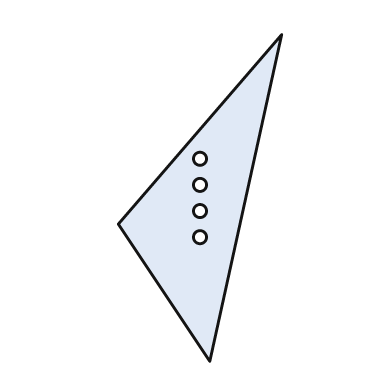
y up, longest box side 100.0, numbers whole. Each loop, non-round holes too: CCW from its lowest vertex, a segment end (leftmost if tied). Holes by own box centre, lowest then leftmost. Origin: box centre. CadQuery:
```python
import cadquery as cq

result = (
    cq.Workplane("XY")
    .moveTo(3.0, -50.0)
    .lineTo(25.0, 50.0)
    .lineTo(-25.0, -8.0)
    .close()
    .moveTo(0.0, -12.0)
    .circle(2.0)
    .moveTo(0.0, -4.0)
    .circle(2.0)
    .moveTo(0.0, 4.0)
    .circle(2.0)
    .moveTo(0.0, 12.0)
    .circle(2.0)
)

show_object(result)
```